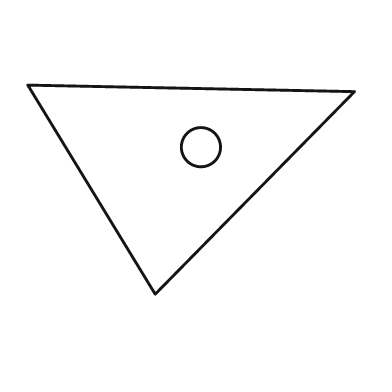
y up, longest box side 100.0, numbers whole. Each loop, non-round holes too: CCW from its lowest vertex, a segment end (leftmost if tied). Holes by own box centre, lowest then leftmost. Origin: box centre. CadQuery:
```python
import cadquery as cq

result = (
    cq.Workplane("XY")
    .moveTo(-11.0, -32.0)
    .lineTo(50.0, 30.0)
    .lineTo(-50.0, 32.0)
    .close()
    .moveTo(3.0, 13.0)
    .circle(6.0)
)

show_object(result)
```